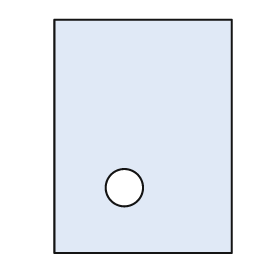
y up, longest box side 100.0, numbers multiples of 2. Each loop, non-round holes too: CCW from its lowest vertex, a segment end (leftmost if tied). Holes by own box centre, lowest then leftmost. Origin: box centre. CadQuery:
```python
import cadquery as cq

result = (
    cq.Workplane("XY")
    .moveTo(-38.0, -50.0)
    .lineTo(38.0, -50.0)
    .lineTo(38.0, 50.0)
    .lineTo(-38.0, 50.0)
    .close()
    .moveTo(-8.0, -22.0)
    .circle(8.0)
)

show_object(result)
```